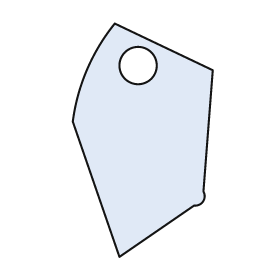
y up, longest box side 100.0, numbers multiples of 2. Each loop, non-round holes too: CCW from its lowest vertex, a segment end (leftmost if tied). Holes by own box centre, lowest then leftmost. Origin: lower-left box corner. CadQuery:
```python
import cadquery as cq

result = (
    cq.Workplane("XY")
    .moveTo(20.0, 0.0)
    .lineTo(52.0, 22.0)
    .threePointArc((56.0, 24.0), (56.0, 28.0))
    .lineTo(60.0, 80.0)
    .lineTo(18.0, 100.0)
    .threePointArc((6.0, 80.0), (0.0, 58.0))
    .close()
    .moveTo(28.0, 82.0)
    .circle(8.0)
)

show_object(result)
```